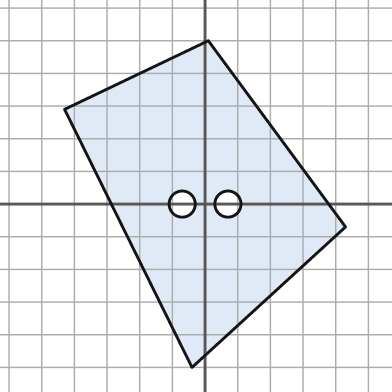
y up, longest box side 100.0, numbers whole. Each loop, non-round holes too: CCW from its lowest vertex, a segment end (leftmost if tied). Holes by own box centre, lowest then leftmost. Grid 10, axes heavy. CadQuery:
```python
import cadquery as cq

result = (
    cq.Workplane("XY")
    .moveTo(-4.0, -50.0)
    .lineTo(43.0, -7.0)
    .lineTo(1.0, 50.0)
    .lineTo(-43.0, 29.0)
    .close()
    .moveTo(-7.0, 0.0)
    .circle(4.0)
    .moveTo(7.0, 0.0)
    .circle(4.0)
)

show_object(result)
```